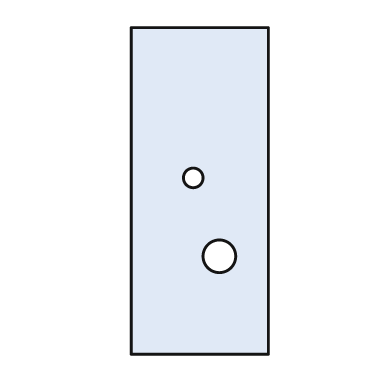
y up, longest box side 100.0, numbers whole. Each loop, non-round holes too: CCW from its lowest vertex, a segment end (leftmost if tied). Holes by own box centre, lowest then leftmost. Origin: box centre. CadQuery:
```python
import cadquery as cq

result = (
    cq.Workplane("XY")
    .moveTo(-21.0, -50.0)
    .lineTo(21.0, -50.0)
    .lineTo(21.0, 50.0)
    .lineTo(-21.0, 50.0)
    .close()
    .moveTo(6.0, -20.0)
    .circle(5.0)
    .moveTo(-2.0, 4.0)
    .circle(3.0)
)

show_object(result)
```